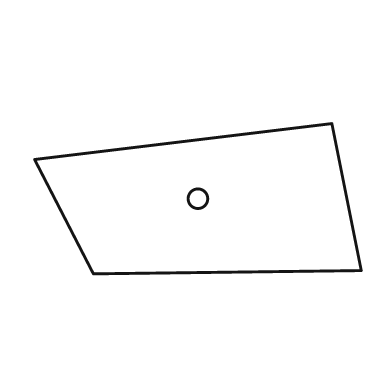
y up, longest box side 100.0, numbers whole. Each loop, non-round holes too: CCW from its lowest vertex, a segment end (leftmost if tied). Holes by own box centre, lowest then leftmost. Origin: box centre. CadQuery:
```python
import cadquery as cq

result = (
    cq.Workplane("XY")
    .moveTo(-32.0, -23.0)
    .lineTo(50.0, -22.0)
    .lineTo(41.0, 23.0)
    .lineTo(-50.0, 12.0)
    .close()
    .moveTo(0.0, 0.0)
    .circle(3.0)
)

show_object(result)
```